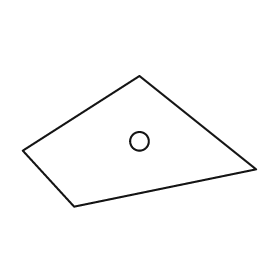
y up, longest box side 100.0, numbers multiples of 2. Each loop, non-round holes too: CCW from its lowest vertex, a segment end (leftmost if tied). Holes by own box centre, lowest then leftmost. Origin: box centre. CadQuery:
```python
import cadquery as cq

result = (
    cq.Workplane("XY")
    .moveTo(-28.0, -28.0)
    .lineTo(50.0, -12.0)
    .lineTo(0.0, 28.0)
    .lineTo(-50.0, -4.0)
    .close()
    .moveTo(0.0, 0.0)
    .circle(4.0)
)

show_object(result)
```